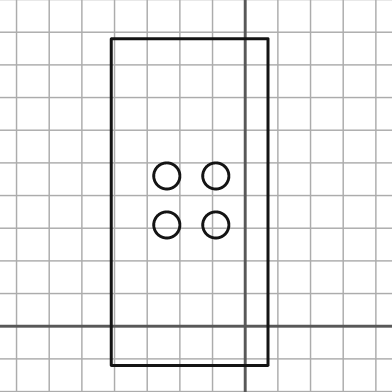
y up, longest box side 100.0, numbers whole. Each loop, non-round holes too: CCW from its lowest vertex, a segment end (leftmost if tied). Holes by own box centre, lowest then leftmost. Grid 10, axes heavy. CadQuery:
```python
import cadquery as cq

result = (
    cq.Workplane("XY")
    .moveTo(-41.0, -12.0)
    .lineTo(7.0, -12.0)
    .lineTo(7.0, 88.0)
    .lineTo(-41.0, 88.0)
    .close()
    .moveTo(-24.0, 31.0)
    .circle(4.0)
    .moveTo(-9.0, 31.0)
    .circle(4.0)
    .moveTo(-24.0, 46.0)
    .circle(4.0)
    .moveTo(-9.0, 46.0)
    .circle(4.0)
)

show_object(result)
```